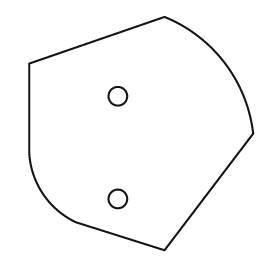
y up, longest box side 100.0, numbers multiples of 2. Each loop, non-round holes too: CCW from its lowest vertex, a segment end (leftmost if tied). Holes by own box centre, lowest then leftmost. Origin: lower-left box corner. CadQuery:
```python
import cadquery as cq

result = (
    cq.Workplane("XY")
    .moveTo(58.0, 0.0)
    .lineTo(96.0, 50.0)
    .threePointArc((84.0, 80.0), (58.0, 100.0))
    .lineTo(0.0, 80.0)
    .lineTo(0.0, 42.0)
    .threePointArc((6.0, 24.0), (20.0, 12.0))
    .close()
    .moveTo(38.0, 22.0)
    .circle(4.0)
    .moveTo(38.0, 66.0)
    .circle(4.0)
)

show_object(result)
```